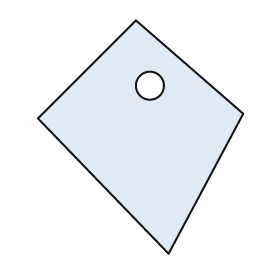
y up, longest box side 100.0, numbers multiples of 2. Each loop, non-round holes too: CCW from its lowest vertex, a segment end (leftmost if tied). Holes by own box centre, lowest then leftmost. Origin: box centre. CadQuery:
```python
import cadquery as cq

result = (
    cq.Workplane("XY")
    .moveTo(12.0, -50.0)
    .lineTo(44.0, 10.0)
    .lineTo(-2.0, 50.0)
    .lineTo(-44.0, 8.0)
    .close()
    .moveTo(4.0, 22.0)
    .circle(6.0)
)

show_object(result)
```